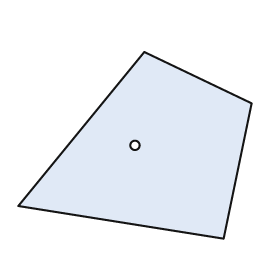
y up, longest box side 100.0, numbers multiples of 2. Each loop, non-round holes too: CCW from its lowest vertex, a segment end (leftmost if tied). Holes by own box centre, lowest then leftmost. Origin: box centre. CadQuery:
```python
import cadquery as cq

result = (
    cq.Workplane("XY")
    .moveTo(38.0, -40.0)
    .lineTo(50.0, 18.0)
    .lineTo(4.0, 40.0)
    .lineTo(-50.0, -26.0)
    .close()
    .moveTo(0.0, 0.0)
    .circle(2.0)
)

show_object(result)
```